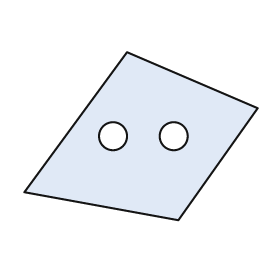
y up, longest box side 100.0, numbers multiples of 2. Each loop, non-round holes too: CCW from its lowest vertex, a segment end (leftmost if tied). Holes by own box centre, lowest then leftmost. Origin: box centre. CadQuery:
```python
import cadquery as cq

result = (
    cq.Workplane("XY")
    .moveTo(16.0, -36.0)
    .lineTo(50.0, 12.0)
    .lineTo(-6.0, 36.0)
    .lineTo(-50.0, -24.0)
    .close()
    .moveTo(-12.0, 0.0)
    .circle(6.0)
    .moveTo(14.0, 0.0)
    .circle(6.0)
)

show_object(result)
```